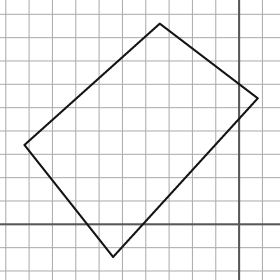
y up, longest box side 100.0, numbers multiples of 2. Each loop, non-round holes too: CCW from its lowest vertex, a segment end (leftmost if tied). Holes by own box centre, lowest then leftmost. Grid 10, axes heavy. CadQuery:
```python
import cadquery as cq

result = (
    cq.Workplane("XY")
    .moveTo(-54.0, -14.0)
    .lineTo(8.0, 54.0)
    .lineTo(-34.0, 86.0)
    .lineTo(-92.0, 34.0)
    .close()
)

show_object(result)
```